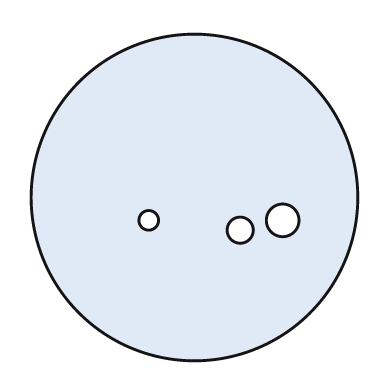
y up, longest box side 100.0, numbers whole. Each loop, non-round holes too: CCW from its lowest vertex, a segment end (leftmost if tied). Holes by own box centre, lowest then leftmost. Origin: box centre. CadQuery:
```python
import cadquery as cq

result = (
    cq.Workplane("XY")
    .moveTo(0.0, 0.0)
    .circle(50.0)
    .moveTo(14.0, -10.0)
    .circle(4.0)
    .moveTo(-14.0, -7.0)
    .circle(3.0)
    .moveTo(27.0, -7.0)
    .circle(5.0)
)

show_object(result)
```